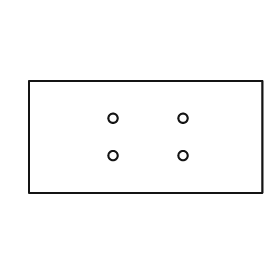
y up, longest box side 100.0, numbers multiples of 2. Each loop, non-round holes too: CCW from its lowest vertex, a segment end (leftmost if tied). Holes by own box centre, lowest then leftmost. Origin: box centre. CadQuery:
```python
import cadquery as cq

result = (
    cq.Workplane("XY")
    .moveTo(-50.0, -24.0)
    .lineTo(50.0, -24.0)
    .lineTo(50.0, 24.0)
    .lineTo(-50.0, 24.0)
    .close()
    .moveTo(-14.0, -8.0)
    .circle(2.0)
    .moveTo(16.0, -8.0)
    .circle(2.0)
    .moveTo(-14.0, 8.0)
    .circle(2.0)
    .moveTo(16.0, 8.0)
    .circle(2.0)
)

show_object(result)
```